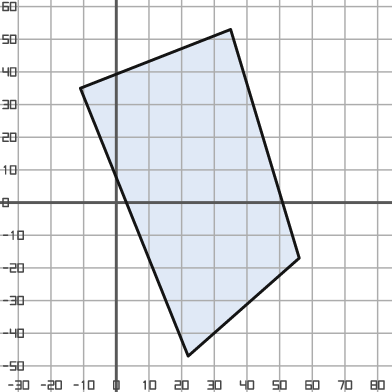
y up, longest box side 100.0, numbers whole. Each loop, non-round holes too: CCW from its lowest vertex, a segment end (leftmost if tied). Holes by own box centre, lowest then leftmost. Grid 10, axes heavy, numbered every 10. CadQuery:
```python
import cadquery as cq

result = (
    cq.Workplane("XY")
    .moveTo(22.0, -47.0)
    .lineTo(56.0, -17.0)
    .lineTo(35.0, 53.0)
    .lineTo(-11.0, 35.0)
    .close()
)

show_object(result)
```